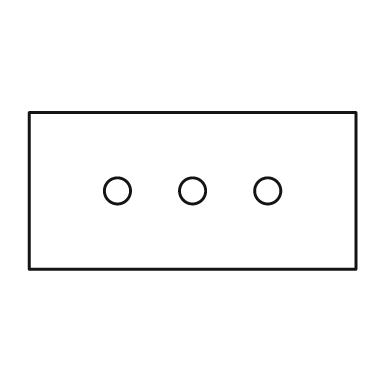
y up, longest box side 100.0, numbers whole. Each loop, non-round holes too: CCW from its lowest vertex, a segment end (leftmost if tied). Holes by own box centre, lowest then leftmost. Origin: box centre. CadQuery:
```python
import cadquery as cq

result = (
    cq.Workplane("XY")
    .moveTo(-50.0, -24.0)
    .lineTo(50.0, -24.0)
    .lineTo(50.0, 24.0)
    .lineTo(-50.0, 24.0)
    .close()
    .moveTo(-23.0, 0.0)
    .circle(4.0)
    .moveTo(0.0, 0.0)
    .circle(4.0)
    .moveTo(23.0, 0.0)
    .circle(4.0)
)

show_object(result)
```